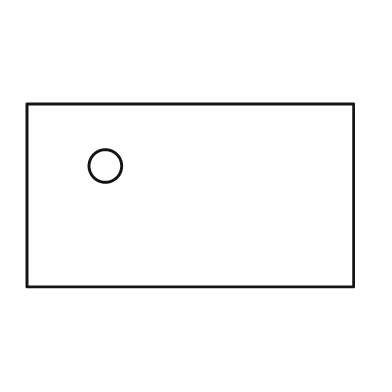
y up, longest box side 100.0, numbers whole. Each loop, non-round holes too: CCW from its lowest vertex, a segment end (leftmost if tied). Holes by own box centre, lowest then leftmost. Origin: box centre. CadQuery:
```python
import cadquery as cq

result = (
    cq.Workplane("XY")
    .moveTo(-50.0, -28.0)
    .lineTo(50.0, -28.0)
    .lineTo(50.0, 28.0)
    .lineTo(-50.0, 28.0)
    .close()
    .moveTo(-26.0, 9.0)
    .circle(5.0)
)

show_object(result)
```